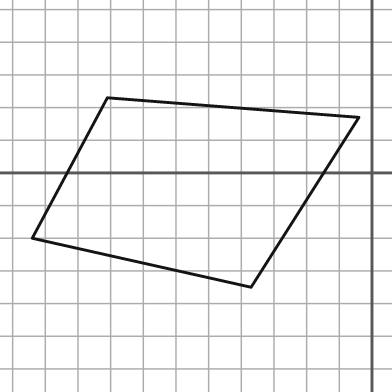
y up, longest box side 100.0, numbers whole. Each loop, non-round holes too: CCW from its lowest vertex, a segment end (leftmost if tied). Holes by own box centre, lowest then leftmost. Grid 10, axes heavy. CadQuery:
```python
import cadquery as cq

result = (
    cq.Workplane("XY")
    .moveTo(-37.0, -35.0)
    .lineTo(-4.0, 17.0)
    .lineTo(-81.0, 23.0)
    .lineTo(-104.0, -20.0)
    .close()
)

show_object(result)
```